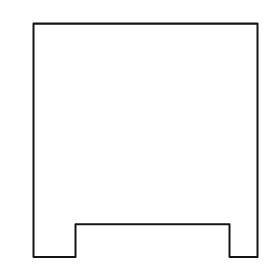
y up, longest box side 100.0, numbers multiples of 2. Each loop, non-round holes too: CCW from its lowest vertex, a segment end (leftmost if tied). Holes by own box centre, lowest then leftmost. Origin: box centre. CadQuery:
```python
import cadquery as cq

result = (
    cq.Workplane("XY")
    .moveTo(-48.0, -50.0)
    .lineTo(-30.0, -50.0)
    .lineTo(-30.0, -36.0)
    .lineTo(36.0, -36.0)
    .lineTo(36.0, -50.0)
    .lineTo(48.0, -50.0)
    .lineTo(48.0, 50.0)
    .lineTo(-48.0, 50.0)
    .close()
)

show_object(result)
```